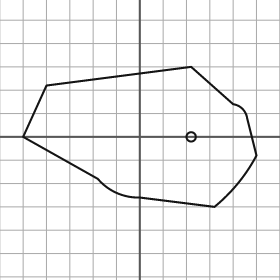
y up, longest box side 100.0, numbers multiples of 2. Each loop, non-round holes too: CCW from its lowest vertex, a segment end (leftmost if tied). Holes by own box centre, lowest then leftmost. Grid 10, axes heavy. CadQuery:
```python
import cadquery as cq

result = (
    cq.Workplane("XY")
    .moveTo(32.0, -30.0)
    .threePointArc((42.0, -20.0), (50.0, -8.0))
    .lineTo(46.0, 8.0)
    .threePointArc((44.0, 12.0), (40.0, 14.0))
    .lineTo(22.0, 30.0)
    .lineTo(-40.0, 22.0)
    .lineTo(-50.0, 0.0)
    .lineTo(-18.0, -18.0)
    .threePointArc((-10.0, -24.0), (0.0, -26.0))
    .close()
    .moveTo(22.0, 0.0)
    .circle(2.0)
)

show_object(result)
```